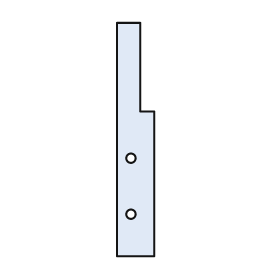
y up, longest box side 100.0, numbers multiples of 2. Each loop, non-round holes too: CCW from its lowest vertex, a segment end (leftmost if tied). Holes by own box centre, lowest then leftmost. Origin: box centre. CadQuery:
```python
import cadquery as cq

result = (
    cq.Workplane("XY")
    .moveTo(-8.0, -50.0)
    .lineTo(8.0, -50.0)
    .lineTo(8.0, 12.0)
    .lineTo(2.0, 12.0)
    .lineTo(2.0, 50.0)
    .lineTo(-8.0, 50.0)
    .close()
    .moveTo(-2.0, -32.0)
    .circle(2.0)
    .moveTo(-2.0, -8.0)
    .circle(2.0)
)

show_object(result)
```